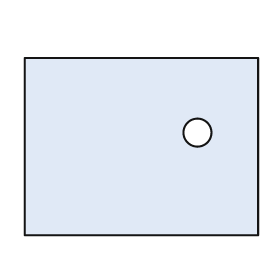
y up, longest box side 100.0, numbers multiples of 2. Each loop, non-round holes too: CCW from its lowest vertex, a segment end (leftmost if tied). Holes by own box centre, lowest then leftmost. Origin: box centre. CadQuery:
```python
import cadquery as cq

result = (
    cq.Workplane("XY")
    .moveTo(-50.0, -38.0)
    .lineTo(50.0, -38.0)
    .lineTo(50.0, 38.0)
    .lineTo(-50.0, 38.0)
    .close()
    .moveTo(24.0, 6.0)
    .circle(6.0)
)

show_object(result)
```